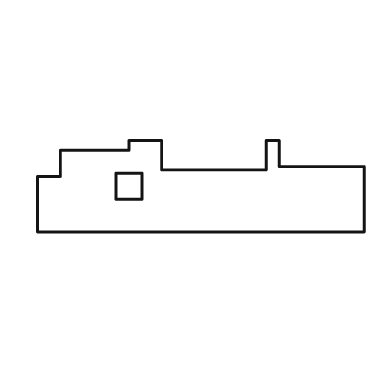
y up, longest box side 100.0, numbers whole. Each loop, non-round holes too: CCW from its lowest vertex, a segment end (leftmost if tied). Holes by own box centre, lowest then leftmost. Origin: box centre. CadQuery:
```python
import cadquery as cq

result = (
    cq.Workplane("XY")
    .moveTo(-50.0, -14.0)
    .lineTo(50.0, -14.0)
    .lineTo(50.0, 6.0)
    .lineTo(24.0, 6.0)
    .lineTo(24.0, 14.0)
    .lineTo(20.0, 14.0)
    .lineTo(20.0, 5.0)
    .lineTo(-12.0, 5.0)
    .lineTo(-12.0, 14.0)
    .lineTo(-22.0, 14.0)
    .lineTo(-22.0, 11.0)
    .lineTo(-43.0, 11.0)
    .lineTo(-43.0, 3.0)
    .lineTo(-50.0, 3.0)
    .close()
    .moveTo(-26.0, -4.0)
    .lineTo(-18.0, -4.0)
    .lineTo(-18.0, 4.0)
    .lineTo(-26.0, 4.0)
    .close()
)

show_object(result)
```